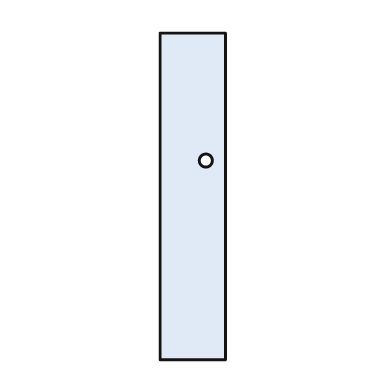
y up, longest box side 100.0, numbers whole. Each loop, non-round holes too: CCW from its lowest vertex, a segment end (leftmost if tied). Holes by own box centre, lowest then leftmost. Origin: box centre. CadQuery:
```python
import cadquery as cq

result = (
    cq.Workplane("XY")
    .moveTo(-10.0, -50.0)
    .lineTo(10.0, -50.0)
    .lineTo(10.0, 50.0)
    .lineTo(-10.0, 50.0)
    .close()
    .moveTo(4.0, 11.0)
    .circle(2.0)
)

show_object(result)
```